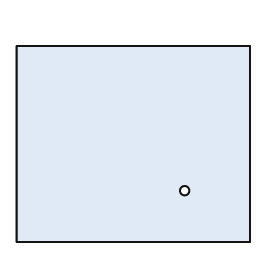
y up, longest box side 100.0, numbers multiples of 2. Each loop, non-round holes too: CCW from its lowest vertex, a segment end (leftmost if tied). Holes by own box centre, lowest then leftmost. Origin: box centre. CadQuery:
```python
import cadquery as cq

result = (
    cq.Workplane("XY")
    .moveTo(-50.0, -42.0)
    .lineTo(50.0, -42.0)
    .lineTo(50.0, 42.0)
    .lineTo(-50.0, 42.0)
    .close()
    .moveTo(22.0, -20.0)
    .circle(2.0)
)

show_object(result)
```